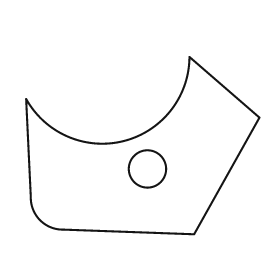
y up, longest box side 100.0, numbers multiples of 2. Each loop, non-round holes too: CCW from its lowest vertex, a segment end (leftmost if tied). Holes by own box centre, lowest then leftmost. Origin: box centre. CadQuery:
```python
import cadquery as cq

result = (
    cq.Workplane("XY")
    .moveTo(22.0, -38.0)
    .lineTo(50.0, 12.0)
    .lineTo(20.0, 38.0)
    .threePointArc((-8.0, 2.0), (-50.0, 20.0))
    .lineTo(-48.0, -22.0)
    .threePointArc((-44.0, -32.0), (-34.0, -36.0))
    .close()
    .moveTo(2.0, -10.0)
    .circle(8.0)
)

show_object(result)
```